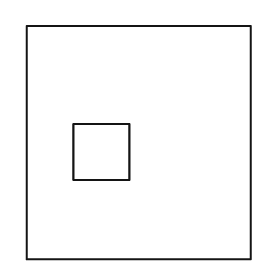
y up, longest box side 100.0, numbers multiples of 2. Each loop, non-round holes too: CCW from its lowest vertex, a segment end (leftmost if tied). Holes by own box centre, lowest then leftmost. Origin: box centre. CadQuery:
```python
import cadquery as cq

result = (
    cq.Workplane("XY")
    .moveTo(-48.0, -50.0)
    .lineTo(48.0, -50.0)
    .lineTo(48.0, 50.0)
    .lineTo(-48.0, 50.0)
    .close()
    .moveTo(-28.0, -16.0)
    .lineTo(-4.0, -16.0)
    .lineTo(-4.0, 8.0)
    .lineTo(-28.0, 8.0)
    .close()
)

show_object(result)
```